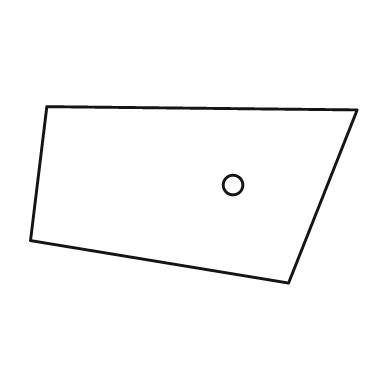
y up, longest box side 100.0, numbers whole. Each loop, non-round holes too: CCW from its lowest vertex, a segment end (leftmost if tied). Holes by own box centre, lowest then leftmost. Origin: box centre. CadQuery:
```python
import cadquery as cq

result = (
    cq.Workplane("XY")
    .moveTo(29.0, -27.0)
    .lineTo(50.0, 26.0)
    .lineTo(-45.0, 27.0)
    .lineTo(-50.0, -14.0)
    .close()
    .moveTo(12.0, 3.0)
    .circle(3.0)
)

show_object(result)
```